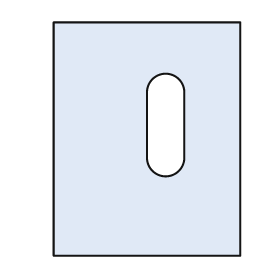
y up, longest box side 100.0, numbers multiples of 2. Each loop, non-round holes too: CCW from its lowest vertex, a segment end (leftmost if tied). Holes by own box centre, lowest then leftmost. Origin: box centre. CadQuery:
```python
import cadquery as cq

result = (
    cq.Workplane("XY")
    .moveTo(-40.0, -50.0)
    .lineTo(40.0, -50.0)
    .lineTo(40.0, 50.0)
    .lineTo(-40.0, 50.0)
    .close()
    .moveTo(0.0, -8.0)
    .threePointArc((8.0, -16.0), (16.0, -8.0))
    .lineTo(16.0, 20.0)
    .threePointArc((8.0, 28.0), (0.0, 20.0))
    .close()
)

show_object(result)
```